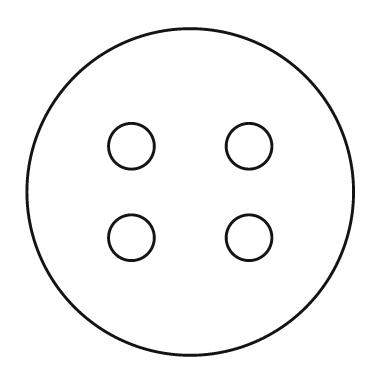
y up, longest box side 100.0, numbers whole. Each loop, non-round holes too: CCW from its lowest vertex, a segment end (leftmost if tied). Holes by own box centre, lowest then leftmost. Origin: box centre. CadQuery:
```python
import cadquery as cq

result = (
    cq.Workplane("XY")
    .moveTo(0.0, 0.0)
    .circle(50.0)
    .moveTo(-18.0, -14.0)
    .circle(7.0)
    .moveTo(18.0, -14.0)
    .circle(7.0)
    .moveTo(-18.0, 14.0)
    .circle(7.0)
    .moveTo(18.0, 14.0)
    .circle(7.0)
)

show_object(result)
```